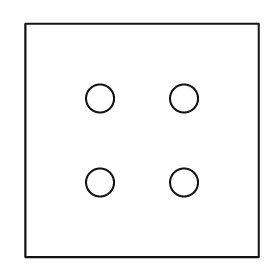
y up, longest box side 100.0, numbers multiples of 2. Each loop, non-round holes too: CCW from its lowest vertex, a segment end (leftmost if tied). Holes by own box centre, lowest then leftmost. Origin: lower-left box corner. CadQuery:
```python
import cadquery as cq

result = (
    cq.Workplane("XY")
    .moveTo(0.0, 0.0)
    .lineTo(100.0, 0.0)
    .lineTo(100.0, 100.0)
    .lineTo(0.0, 100.0)
    .close()
    .moveTo(32.0, 32.0)
    .circle(6.0)
    .moveTo(68.0, 32.0)
    .circle(6.0)
    .moveTo(32.0, 68.0)
    .circle(6.0)
    .moveTo(68.0, 68.0)
    .circle(6.0)
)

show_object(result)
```